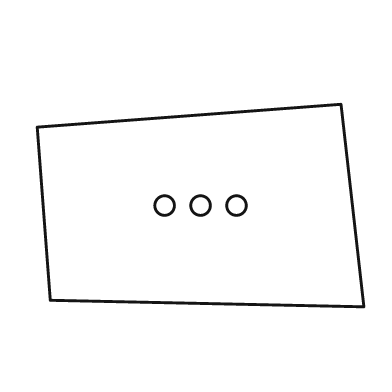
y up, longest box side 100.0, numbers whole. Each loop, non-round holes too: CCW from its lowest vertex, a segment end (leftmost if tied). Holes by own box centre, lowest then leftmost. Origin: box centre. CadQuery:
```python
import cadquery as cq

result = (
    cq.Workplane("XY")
    .moveTo(50.0, -31.0)
    .lineTo(43.0, 31.0)
    .lineTo(-50.0, 24.0)
    .lineTo(-46.0, -29.0)
    .close()
    .moveTo(-11.0, 0.0)
    .circle(3.0)
    .moveTo(0.0, 0.0)
    .circle(3.0)
    .moveTo(11.0, 0.0)
    .circle(3.0)
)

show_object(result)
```